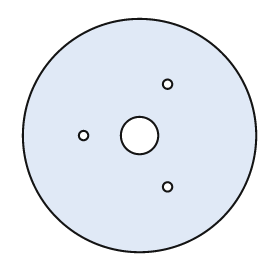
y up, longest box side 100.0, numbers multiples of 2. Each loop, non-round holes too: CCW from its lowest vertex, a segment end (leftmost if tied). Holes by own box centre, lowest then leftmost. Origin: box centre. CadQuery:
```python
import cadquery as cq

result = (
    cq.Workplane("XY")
    .moveTo(0.0, 0.0)
    .circle(50.0)
    .moveTo(12.0, -22.0)
    .circle(2.0)
    .moveTo(-24.0, 0.0)
    .circle(2.0)
    .moveTo(0.0, 0.0)
    .circle(8.0)
    .moveTo(12.0, 22.0)
    .circle(2.0)
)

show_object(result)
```